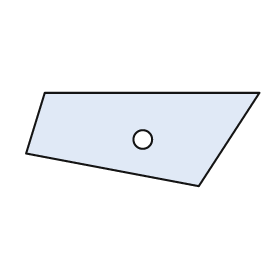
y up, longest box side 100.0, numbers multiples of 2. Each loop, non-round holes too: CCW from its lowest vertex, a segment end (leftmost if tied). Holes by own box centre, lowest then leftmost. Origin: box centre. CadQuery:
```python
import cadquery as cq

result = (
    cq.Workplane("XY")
    .moveTo(24.0, -20.0)
    .lineTo(50.0, 20.0)
    .lineTo(-42.0, 20.0)
    .lineTo(-50.0, -6.0)
    .close()
    .moveTo(0.0, 0.0)
    .circle(4.0)
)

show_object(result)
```